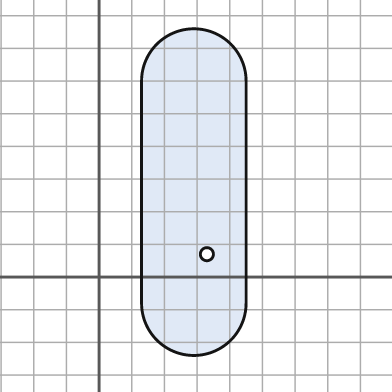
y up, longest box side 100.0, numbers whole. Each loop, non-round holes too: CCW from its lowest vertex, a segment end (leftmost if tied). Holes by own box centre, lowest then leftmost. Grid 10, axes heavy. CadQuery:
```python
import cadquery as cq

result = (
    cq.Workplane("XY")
    .moveTo(13.0, -8.0)
    .threePointArc((29.0, -24.0), (45.0, -8.0))
    .lineTo(45.0, 60.0)
    .threePointArc((29.0, 76.0), (13.0, 60.0))
    .close()
    .moveTo(33.0, 7.0)
    .circle(2.0)
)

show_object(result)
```